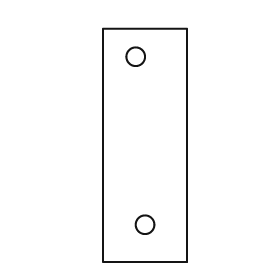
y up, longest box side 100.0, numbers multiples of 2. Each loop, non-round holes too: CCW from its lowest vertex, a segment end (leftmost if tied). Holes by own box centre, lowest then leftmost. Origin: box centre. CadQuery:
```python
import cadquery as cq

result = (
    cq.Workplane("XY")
    .moveTo(-18.0, -50.0)
    .lineTo(18.0, -50.0)
    .lineTo(18.0, 50.0)
    .lineTo(-18.0, 50.0)
    .close()
    .moveTo(0.0, -34.0)
    .circle(4.0)
    .moveTo(-4.0, 38.0)
    .circle(4.0)
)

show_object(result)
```